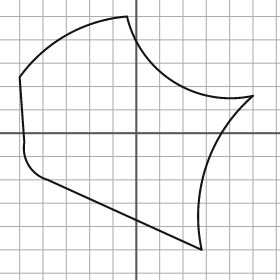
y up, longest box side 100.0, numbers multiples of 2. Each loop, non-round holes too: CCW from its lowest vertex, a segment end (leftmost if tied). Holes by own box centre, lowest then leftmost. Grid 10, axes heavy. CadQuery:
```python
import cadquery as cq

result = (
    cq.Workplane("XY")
    .moveTo(28.0, -50.0)
    .threePointArc((30.0, -14.0), (50.0, 16.0))
    .threePointArc((16.0, 22.0), (-4.0, 50.0))
    .threePointArc((-30.0, 42.0), (-50.0, 24.0))
    .lineTo(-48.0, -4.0)
    .threePointArc((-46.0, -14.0), (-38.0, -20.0))
    .close()
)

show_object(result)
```